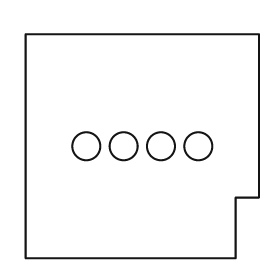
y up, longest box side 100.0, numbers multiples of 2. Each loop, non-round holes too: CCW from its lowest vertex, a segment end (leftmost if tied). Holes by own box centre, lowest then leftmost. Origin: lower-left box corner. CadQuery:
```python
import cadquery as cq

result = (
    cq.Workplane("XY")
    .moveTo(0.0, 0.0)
    .lineTo(90.0, 0.0)
    .lineTo(90.0, 26.0)
    .lineTo(100.0, 26.0)
    .lineTo(100.0, 96.0)
    .lineTo(0.0, 96.0)
    .close()
    .moveTo(26.0, 48.0)
    .circle(6.0)
    .moveTo(42.0, 48.0)
    .circle(6.0)
    .moveTo(58.0, 48.0)
    .circle(6.0)
    .moveTo(74.0, 48.0)
    .circle(6.0)
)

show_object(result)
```